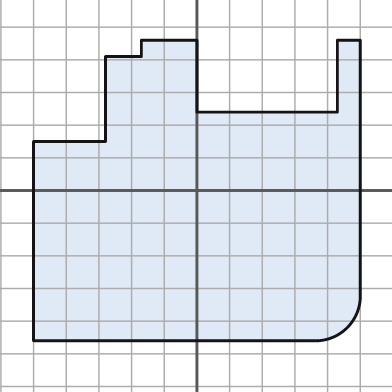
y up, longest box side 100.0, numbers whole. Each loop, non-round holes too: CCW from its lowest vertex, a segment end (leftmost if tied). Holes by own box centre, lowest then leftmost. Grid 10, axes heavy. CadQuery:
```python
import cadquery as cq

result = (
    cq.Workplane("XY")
    .moveTo(-50.0, -46.0)
    .lineTo(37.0, -46.0)
    .threePointArc((46.0, -42.0), (50.0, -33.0))
    .lineTo(50.0, 46.0)
    .lineTo(43.0, 46.0)
    .lineTo(43.0, 24.0)
    .lineTo(0.0, 24.0)
    .lineTo(0.0, 46.0)
    .lineTo(-17.0, 46.0)
    .lineTo(-17.0, 41.0)
    .lineTo(-28.0, 41.0)
    .lineTo(-28.0, 15.0)
    .lineTo(-50.0, 15.0)
    .close()
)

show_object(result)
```